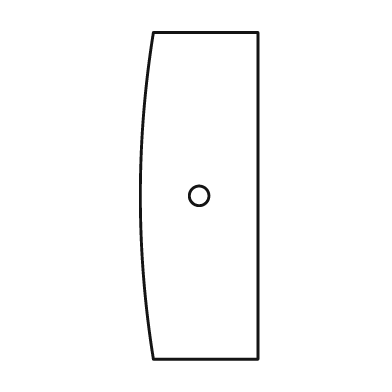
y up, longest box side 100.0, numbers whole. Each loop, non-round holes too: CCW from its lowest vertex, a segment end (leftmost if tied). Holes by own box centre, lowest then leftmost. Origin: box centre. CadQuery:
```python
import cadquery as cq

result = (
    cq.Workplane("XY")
    .moveTo(-14.0, -50.0)
    .lineTo(18.0, -50.0)
    .lineTo(18.0, 50.0)
    .lineTo(-14.0, 50.0)
    .threePointArc((-18.0, 0.0), (-14.0, -50.0))
    .close()
    .moveTo(0.0, 0.0)
    .circle(3.0)
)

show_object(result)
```